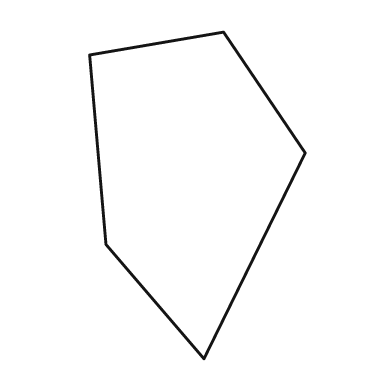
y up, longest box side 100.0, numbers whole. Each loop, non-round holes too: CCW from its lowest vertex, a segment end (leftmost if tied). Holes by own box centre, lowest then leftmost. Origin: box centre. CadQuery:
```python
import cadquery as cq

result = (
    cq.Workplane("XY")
    .moveTo(2.0, -50.0)
    .lineTo(33.0, 13.0)
    .lineTo(8.0, 50.0)
    .lineTo(-33.0, 43.0)
    .lineTo(-28.0, -15.0)
    .close()
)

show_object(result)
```